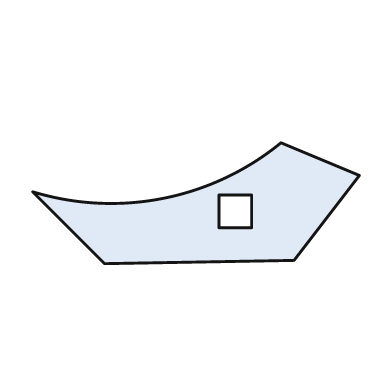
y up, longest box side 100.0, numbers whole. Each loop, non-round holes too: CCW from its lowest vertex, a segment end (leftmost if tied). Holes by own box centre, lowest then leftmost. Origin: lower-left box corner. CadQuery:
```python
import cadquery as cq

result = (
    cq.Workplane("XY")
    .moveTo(22.0, 0.0)
    .lineTo(80.0, 1.0)
    .lineTo(100.0, 27.0)
    .lineTo(76.0, 37.0)
    .threePointArc((40.0, 20.0), (0.0, 22.0))
    .close()
    .moveTo(57.0, 11.0)
    .lineTo(67.0, 11.0)
    .lineTo(67.0, 21.0)
    .lineTo(57.0, 21.0)
    .close()
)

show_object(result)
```